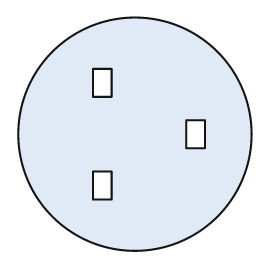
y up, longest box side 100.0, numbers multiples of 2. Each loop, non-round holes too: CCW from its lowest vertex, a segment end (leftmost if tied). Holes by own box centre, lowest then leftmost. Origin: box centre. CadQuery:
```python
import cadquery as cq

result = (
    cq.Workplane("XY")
    .moveTo(0.0, 0.0)
    .circle(50.0)
    .moveTo(-18.0, -28.0)
    .lineTo(-10.0, -28.0)
    .lineTo(-10.0, -16.0)
    .lineTo(-18.0, -16.0)
    .close()
    .moveTo(22.0, -6.0)
    .lineTo(30.0, -6.0)
    .lineTo(30.0, 6.0)
    .lineTo(22.0, 6.0)
    .close()
    .moveTo(-18.0, 16.0)
    .lineTo(-10.0, 16.0)
    .lineTo(-10.0, 28.0)
    .lineTo(-18.0, 28.0)
    .close()
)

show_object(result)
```